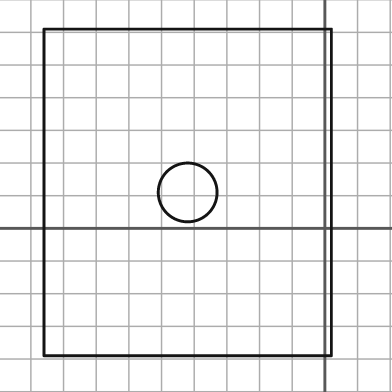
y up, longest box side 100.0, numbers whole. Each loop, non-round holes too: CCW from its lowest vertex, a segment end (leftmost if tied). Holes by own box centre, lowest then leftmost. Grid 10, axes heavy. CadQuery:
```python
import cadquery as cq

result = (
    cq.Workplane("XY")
    .moveTo(-86.0, -39.0)
    .lineTo(2.0, -39.0)
    .lineTo(2.0, 61.0)
    .lineTo(-86.0, 61.0)
    .close()
    .moveTo(-42.0, 11.0)
    .circle(9.0)
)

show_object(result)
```